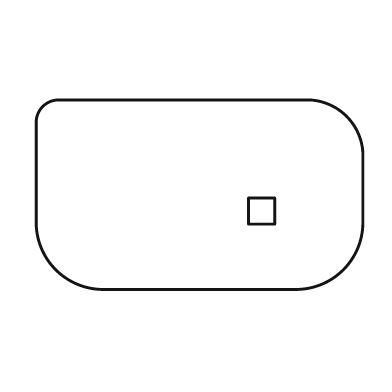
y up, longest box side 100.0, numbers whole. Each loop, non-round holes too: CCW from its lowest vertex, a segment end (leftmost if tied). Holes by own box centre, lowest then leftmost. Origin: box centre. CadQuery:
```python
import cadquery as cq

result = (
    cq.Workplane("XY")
    .moveTo(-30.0, -29.0)
    .lineTo(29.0, -29.0)
    .threePointArc((44.0, -23.0), (50.0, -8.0))
    .lineTo(50.0, 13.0)
    .threePointArc((45.0, 24.0), (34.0, 29.0))
    .lineTo(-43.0, 29.0)
    .threePointArc((-48.0, 27.0), (-50.0, 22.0))
    .lineTo(-50.0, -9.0)
    .threePointArc((-44.0, -23.0), (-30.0, -29.0))
    .close()
    .moveTo(15.0, -9.0)
    .lineTo(23.0, -9.0)
    .lineTo(23.0, -1.0)
    .lineTo(15.0, -1.0)
    .close()
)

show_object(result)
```